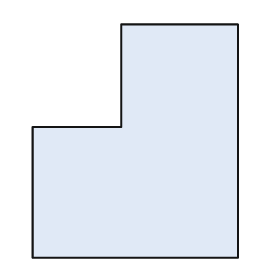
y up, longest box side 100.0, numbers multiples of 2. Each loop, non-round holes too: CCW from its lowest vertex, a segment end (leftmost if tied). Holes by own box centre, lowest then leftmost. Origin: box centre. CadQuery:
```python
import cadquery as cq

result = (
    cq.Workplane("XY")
    .moveTo(-44.0, -50.0)
    .lineTo(44.0, -50.0)
    .lineTo(44.0, 50.0)
    .lineTo(-6.0, 50.0)
    .lineTo(-6.0, 6.0)
    .lineTo(-44.0, 6.0)
    .close()
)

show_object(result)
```